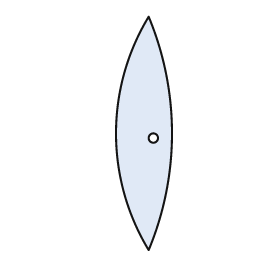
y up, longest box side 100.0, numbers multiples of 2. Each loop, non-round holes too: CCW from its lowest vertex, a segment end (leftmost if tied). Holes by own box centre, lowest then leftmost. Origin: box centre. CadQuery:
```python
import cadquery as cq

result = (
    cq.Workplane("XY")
    .moveTo(2.0, -50.0)
    .threePointArc((12.0, 0.0), (2.0, 50.0))
    .threePointArc((-12.0, 0.0), (2.0, -50.0))
    .close()
    .moveTo(4.0, -2.0)
    .circle(2.0)
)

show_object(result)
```